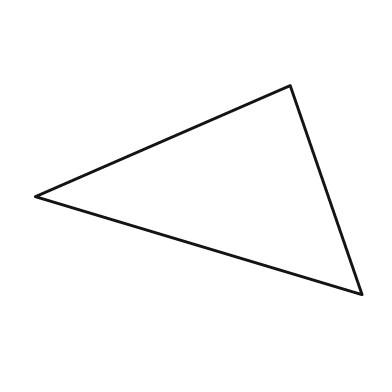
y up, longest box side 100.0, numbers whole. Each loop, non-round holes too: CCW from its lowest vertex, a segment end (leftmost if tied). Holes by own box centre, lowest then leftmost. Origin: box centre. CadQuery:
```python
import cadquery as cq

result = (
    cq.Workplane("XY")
    .moveTo(50.0, -32.0)
    .lineTo(28.0, 32.0)
    .lineTo(-50.0, -2.0)
    .close()
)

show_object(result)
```